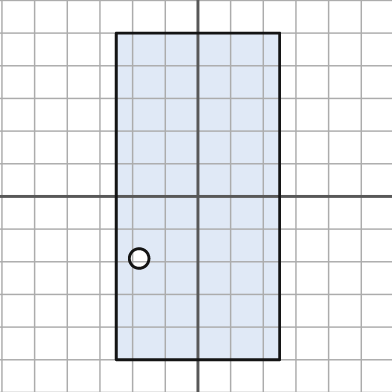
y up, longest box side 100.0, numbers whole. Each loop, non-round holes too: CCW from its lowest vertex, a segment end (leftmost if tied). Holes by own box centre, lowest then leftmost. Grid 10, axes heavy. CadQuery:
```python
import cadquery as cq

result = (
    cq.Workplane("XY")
    .moveTo(-25.0, -50.0)
    .lineTo(25.0, -50.0)
    .lineTo(25.0, 50.0)
    .lineTo(-25.0, 50.0)
    .close()
    .moveTo(-18.0, -19.0)
    .circle(3.0)
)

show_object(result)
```